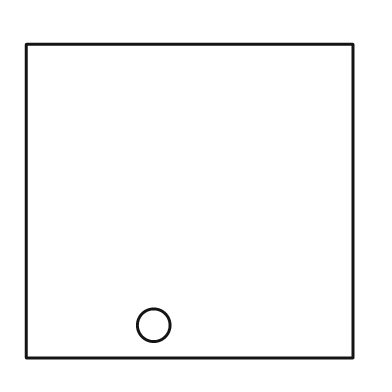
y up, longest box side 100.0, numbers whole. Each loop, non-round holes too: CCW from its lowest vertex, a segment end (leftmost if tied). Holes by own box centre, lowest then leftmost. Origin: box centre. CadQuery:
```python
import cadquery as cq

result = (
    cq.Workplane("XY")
    .moveTo(-50.0, -48.0)
    .lineTo(50.0, -48.0)
    .lineTo(50.0, 48.0)
    .lineTo(-50.0, 48.0)
    .close()
    .moveTo(-11.0, -38.0)
    .circle(5.0)
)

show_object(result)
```